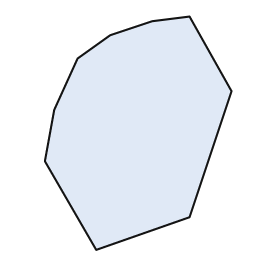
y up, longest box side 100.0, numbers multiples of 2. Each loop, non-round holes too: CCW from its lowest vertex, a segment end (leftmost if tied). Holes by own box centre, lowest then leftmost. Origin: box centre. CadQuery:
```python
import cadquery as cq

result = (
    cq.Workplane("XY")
    .moveTo(-18.0, -50.0)
    .lineTo(22.0, -36.0)
    .lineTo(40.0, 18.0)
    .lineTo(22.0, 50.0)
    .lineTo(6.0, 48.0)
    .lineTo(-12.0, 42.0)
    .lineTo(-26.0, 32.0)
    .lineTo(-36.0, 10.0)
    .lineTo(-40.0, -12.0)
    .close()
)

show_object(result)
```